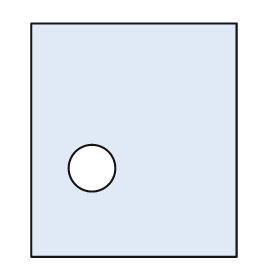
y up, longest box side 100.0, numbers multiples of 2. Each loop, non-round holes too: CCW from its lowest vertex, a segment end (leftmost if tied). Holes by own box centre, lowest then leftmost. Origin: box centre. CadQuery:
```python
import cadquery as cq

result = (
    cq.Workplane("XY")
    .moveTo(-44.0, -50.0)
    .lineTo(44.0, -50.0)
    .lineTo(44.0, 50.0)
    .lineTo(-44.0, 50.0)
    .close()
    .moveTo(-18.0, -12.0)
    .circle(10.0)
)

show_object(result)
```